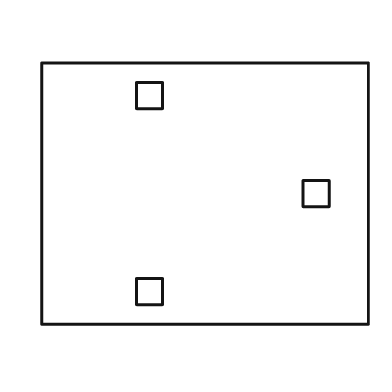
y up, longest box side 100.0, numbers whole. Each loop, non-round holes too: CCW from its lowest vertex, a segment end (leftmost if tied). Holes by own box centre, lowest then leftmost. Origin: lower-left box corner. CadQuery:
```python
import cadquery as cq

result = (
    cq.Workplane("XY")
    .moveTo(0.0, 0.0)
    .lineTo(100.0, 0.0)
    .lineTo(100.0, 80.0)
    .lineTo(0.0, 80.0)
    .close()
    .moveTo(29.0, 6.0)
    .lineTo(37.0, 6.0)
    .lineTo(37.0, 14.0)
    .lineTo(29.0, 14.0)
    .close()
    .moveTo(80.0, 36.0)
    .lineTo(88.0, 36.0)
    .lineTo(88.0, 44.0)
    .lineTo(80.0, 44.0)
    .close()
    .moveTo(29.0, 66.0)
    .lineTo(37.0, 66.0)
    .lineTo(37.0, 74.0)
    .lineTo(29.0, 74.0)
    .close()
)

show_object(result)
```